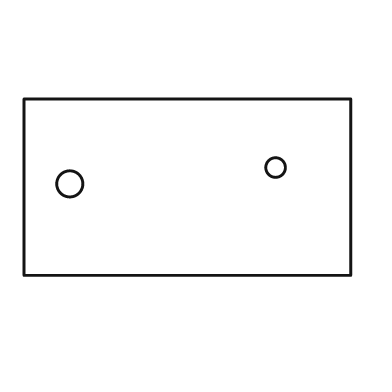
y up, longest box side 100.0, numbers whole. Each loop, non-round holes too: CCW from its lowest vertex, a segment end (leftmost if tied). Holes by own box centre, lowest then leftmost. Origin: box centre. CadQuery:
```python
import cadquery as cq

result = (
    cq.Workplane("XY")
    .moveTo(-50.0, -27.0)
    .lineTo(50.0, -27.0)
    .lineTo(50.0, 27.0)
    .lineTo(-50.0, 27.0)
    .close()
    .moveTo(-36.0, 1.0)
    .circle(4.0)
    .moveTo(27.0, 6.0)
    .circle(3.0)
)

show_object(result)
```